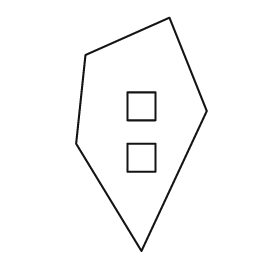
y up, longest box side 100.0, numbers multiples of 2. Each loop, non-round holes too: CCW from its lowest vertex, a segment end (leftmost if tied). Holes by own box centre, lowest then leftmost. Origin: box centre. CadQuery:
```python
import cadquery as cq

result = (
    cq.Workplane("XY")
    .moveTo(0.0, -50.0)
    .lineTo(28.0, 10.0)
    .lineTo(12.0, 50.0)
    .lineTo(-24.0, 34.0)
    .lineTo(-28.0, -4.0)
    .close()
    .moveTo(-6.0, -16.0)
    .lineTo(6.0, -16.0)
    .lineTo(6.0, -4.0)
    .lineTo(-6.0, -4.0)
    .close()
    .moveTo(-6.0, 6.0)
    .lineTo(6.0, 6.0)
    .lineTo(6.0, 18.0)
    .lineTo(-6.0, 18.0)
    .close()
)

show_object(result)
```